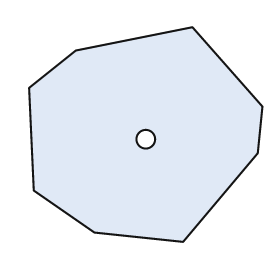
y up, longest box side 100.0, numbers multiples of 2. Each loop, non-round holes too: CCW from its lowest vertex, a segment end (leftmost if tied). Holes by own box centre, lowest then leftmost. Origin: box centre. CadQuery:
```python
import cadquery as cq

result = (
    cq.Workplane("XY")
    .moveTo(16.0, -46.0)
    .lineTo(48.0, -8.0)
    .lineTo(50.0, 12.0)
    .lineTo(20.0, 46.0)
    .lineTo(-30.0, 36.0)
    .lineTo(-50.0, 20.0)
    .lineTo(-48.0, -24.0)
    .lineTo(-22.0, -42.0)
    .close()
    .moveTo(0.0, -2.0)
    .circle(4.0)
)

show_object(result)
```